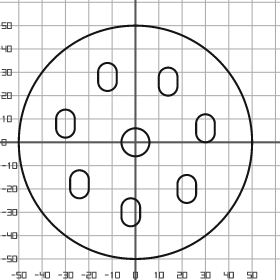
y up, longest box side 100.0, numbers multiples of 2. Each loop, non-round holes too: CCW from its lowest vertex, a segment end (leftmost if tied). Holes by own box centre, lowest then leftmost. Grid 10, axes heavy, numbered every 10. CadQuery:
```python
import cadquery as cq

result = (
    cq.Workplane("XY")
    .moveTo(0.0, 0.0)
    .circle(50.0)
    .moveTo(-6.0, -32.0)
    .threePointArc((-2.0, -36.0), (2.0, -32.0))
    .lineTo(2.0, -28.0)
    .threePointArc((-2.0, -24.0), (-6.0, -28.0))
    .close()
    .moveTo(18.0, -22.0)
    .threePointArc((22.0, -26.0), (26.0, -22.0))
    .lineTo(26.0, -18.0)
    .threePointArc((22.0, -14.0), (18.0, -18.0))
    .close()
    .moveTo(-28.0, -20.0)
    .threePointArc((-24.0, -24.0), (-20.0, -20.0))
    .lineTo(-20.0, -16.0)
    .threePointArc((-24.0, -12.0), (-28.0, -16.0))
    .close()
    .moveTo(0.0, 0.0)
    .circle(6.0)
    .moveTo(26.0, 4.0)
    .threePointArc((30.0, 0.0), (34.0, 4.0))
    .lineTo(34.0, 8.0)
    .threePointArc((30.0, 12.0), (26.0, 8.0))
    .close()
    .moveTo(-34.0, 6.0)
    .threePointArc((-30.0, 2.0), (-26.0, 6.0))
    .lineTo(-26.0, 10.0)
    .threePointArc((-30.0, 14.0), (-34.0, 10.0))
    .close()
    .moveTo(10.0, 24.0)
    .threePointArc((14.0, 20.0), (18.0, 24.0))
    .lineTo(18.0, 28.0)
    .threePointArc((14.0, 32.0), (10.0, 28.0))
    .close()
    .moveTo(-16.0, 26.0)
    .threePointArc((-12.0, 22.0), (-8.0, 26.0))
    .lineTo(-8.0, 30.0)
    .threePointArc((-12.0, 34.0), (-16.0, 30.0))
    .close()
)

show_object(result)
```